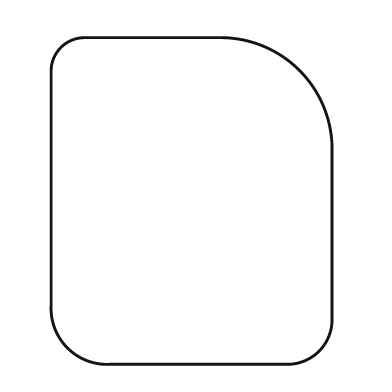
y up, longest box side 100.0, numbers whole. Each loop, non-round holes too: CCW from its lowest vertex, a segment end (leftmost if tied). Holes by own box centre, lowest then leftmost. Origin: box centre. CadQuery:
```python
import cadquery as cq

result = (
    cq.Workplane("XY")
    .moveTo(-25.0, -50.0)
    .lineTo(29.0, -50.0)
    .threePointArc((39.0, -46.0), (43.0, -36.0))
    .lineTo(43.0, 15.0)
    .threePointArc((33.0, 40.0), (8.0, 50.0))
    .lineTo(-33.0, 50.0)
    .threePointArc((-40.0, 47.0), (-43.0, 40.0))
    .lineTo(-43.0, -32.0)
    .threePointArc((-38.0, -45.0), (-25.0, -50.0))
    .close()
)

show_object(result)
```